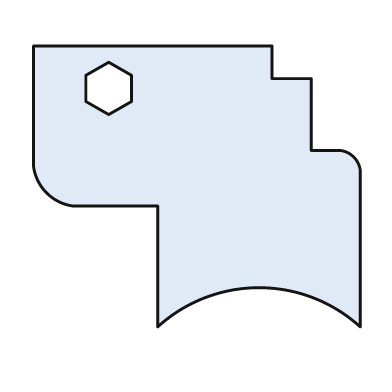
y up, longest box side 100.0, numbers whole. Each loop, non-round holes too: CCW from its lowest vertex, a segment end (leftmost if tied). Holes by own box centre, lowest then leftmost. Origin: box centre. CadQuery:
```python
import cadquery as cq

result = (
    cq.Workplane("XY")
    .moveTo(-12.0, -43.0)
    .threePointArc((19.0, -31.0), (50.0, -43.0))
    .lineTo(50.0, 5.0)
    .threePointArc((48.0, 9.0), (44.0, 11.0))
    .lineTo(35.0, 11.0)
    .lineTo(35.0, 33.0)
    .lineTo(23.0, 33.0)
    .lineTo(23.0, 43.0)
    .lineTo(-50.0, 43.0)
    .lineTo(-50.0, 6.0)
    .threePointArc((-46.0, -2.0), (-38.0, -6.0))
    .lineTo(-12.0, -6.0)
    .close()
    .moveTo(-27.0, 22.0)
    .lineTo(-20.0, 26.0)
    .lineTo(-20.0, 34.0)
    .lineTo(-27.0, 38.0)
    .lineTo(-34.0, 34.0)
    .lineTo(-34.0, 26.0)
    .close()
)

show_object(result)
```